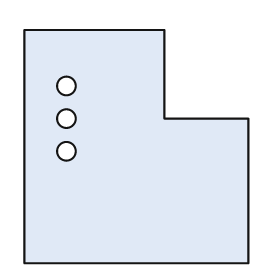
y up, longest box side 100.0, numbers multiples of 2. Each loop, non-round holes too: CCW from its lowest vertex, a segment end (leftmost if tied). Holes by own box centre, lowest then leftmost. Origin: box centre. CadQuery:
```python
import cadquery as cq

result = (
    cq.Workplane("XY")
    .moveTo(-48.0, -50.0)
    .lineTo(48.0, -50.0)
    .lineTo(48.0, 12.0)
    .lineTo(12.0, 12.0)
    .lineTo(12.0, 50.0)
    .lineTo(-48.0, 50.0)
    .close()
    .moveTo(-30.0, -2.0)
    .circle(4.0)
    .moveTo(-30.0, 12.0)
    .circle(4.0)
    .moveTo(-30.0, 26.0)
    .circle(4.0)
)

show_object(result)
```